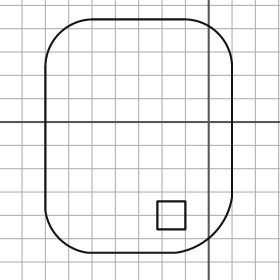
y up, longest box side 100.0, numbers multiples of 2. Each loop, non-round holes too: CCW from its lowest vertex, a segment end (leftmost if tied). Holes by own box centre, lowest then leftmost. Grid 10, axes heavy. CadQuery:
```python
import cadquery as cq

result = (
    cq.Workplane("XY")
    .moveTo(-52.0, -56.0)
    .lineTo(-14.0, -56.0)
    .threePointArc((2.0, -48.0), (10.0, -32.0))
    .lineTo(10.0, 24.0)
    .threePointArc((4.0, 38.0), (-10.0, 44.0))
    .lineTo(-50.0, 44.0)
    .threePointArc((-64.0, 38.0), (-70.0, 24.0))
    .lineTo(-70.0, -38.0)
    .threePointArc((-64.0, -50.0), (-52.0, -56.0))
    .close()
    .moveTo(-22.0, -46.0)
    .lineTo(-10.0, -46.0)
    .lineTo(-10.0, -34.0)
    .lineTo(-22.0, -34.0)
    .close()
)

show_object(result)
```